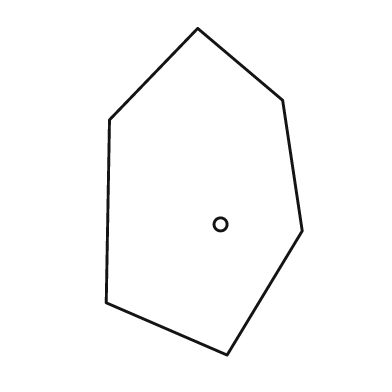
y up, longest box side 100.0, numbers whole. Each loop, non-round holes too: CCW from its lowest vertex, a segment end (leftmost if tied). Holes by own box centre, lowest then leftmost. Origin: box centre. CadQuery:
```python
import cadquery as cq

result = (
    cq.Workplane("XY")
    .moveTo(7.0, -50.0)
    .lineTo(30.0, -12.0)
    .lineTo(24.0, 28.0)
    .lineTo(-2.0, 50.0)
    .lineTo(-29.0, 22.0)
    .lineTo(-30.0, -34.0)
    .close()
    .moveTo(5.0, -10.0)
    .circle(2.0)
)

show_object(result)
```